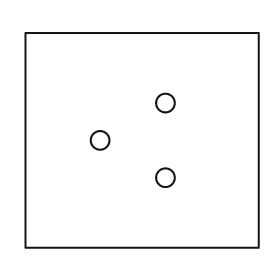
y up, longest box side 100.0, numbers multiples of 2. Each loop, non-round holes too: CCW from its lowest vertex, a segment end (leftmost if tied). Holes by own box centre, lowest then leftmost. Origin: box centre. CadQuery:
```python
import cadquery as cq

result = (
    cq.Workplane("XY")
    .moveTo(-50.0, -46.0)
    .lineTo(50.0, -46.0)
    .lineTo(50.0, 46.0)
    .lineTo(-50.0, 46.0)
    .close()
    .moveTo(10.0, -16.0)
    .circle(4.0)
    .moveTo(-18.0, 0.0)
    .circle(4.0)
    .moveTo(10.0, 16.0)
    .circle(4.0)
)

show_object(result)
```